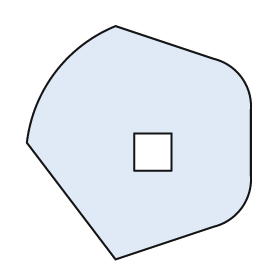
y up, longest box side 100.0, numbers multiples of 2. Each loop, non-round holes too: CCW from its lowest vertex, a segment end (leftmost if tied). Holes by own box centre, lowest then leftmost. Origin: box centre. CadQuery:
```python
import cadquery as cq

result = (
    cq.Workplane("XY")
    .moveTo(-10.0, -50.0)
    .lineTo(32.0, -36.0)
    .threePointArc((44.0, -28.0), (48.0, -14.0))
    .lineTo(48.0, 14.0)
    .threePointArc((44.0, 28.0), (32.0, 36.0))
    .lineTo(-10.0, 50.0)
    .threePointArc((-36.0, 30.0), (-48.0, 0.0))
    .close()
    .moveTo(-2.0, -12.0)
    .lineTo(14.0, -12.0)
    .lineTo(14.0, 4.0)
    .lineTo(-2.0, 4.0)
    .close()
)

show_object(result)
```